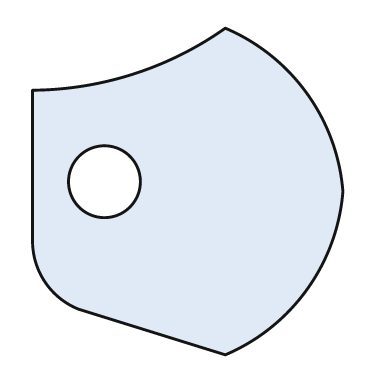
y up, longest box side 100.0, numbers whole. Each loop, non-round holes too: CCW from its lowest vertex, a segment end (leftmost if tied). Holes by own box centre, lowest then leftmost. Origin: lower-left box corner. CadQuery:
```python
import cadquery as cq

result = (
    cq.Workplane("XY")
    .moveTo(59.0, 0.0)
    .threePointArc((84.0, 20.0), (95.0, 50.0))
    .threePointArc((84.0, 80.0), (59.0, 100.0))
    .threePointArc((31.0, 86.0), (0.0, 81.0))
    .lineTo(0.0, 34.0)
    .threePointArc((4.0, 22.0), (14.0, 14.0))
    .close()
    .moveTo(22.0, 53.0)
    .circle(11.0)
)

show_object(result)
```